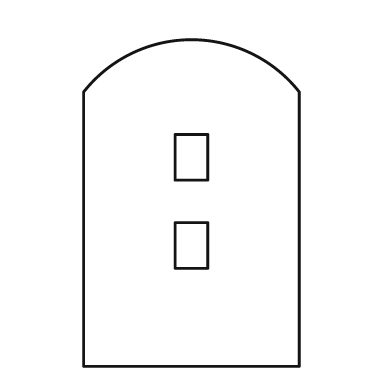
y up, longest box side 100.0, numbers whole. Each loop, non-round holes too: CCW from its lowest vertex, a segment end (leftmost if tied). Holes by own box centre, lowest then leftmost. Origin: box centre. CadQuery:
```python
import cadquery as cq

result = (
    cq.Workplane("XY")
    .moveTo(-33.0, -50.0)
    .lineTo(33.0, -50.0)
    .lineTo(33.0, 34.0)
    .threePointArc((0.0, 50.0), (-33.0, 34.0))
    .close()
    .moveTo(-5.0, -20.0)
    .lineTo(5.0, -20.0)
    .lineTo(5.0, -6.0)
    .lineTo(-5.0, -6.0)
    .close()
    .moveTo(-5.0, 7.0)
    .lineTo(5.0, 7.0)
    .lineTo(5.0, 21.0)
    .lineTo(-5.0, 21.0)
    .close()
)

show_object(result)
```